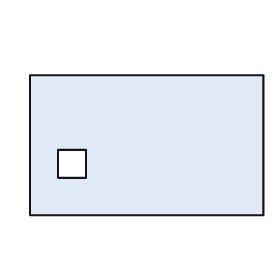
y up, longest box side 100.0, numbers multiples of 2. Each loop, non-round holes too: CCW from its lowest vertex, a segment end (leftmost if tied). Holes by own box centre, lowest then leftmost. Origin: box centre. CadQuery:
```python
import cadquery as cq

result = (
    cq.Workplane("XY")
    .moveTo(-50.0, -30.0)
    .lineTo(50.0, -30.0)
    .lineTo(50.0, 30.0)
    .lineTo(-50.0, 30.0)
    .close()
    .moveTo(-38.0, -14.0)
    .lineTo(-26.0, -14.0)
    .lineTo(-26.0, -2.0)
    .lineTo(-38.0, -2.0)
    .close()
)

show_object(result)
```